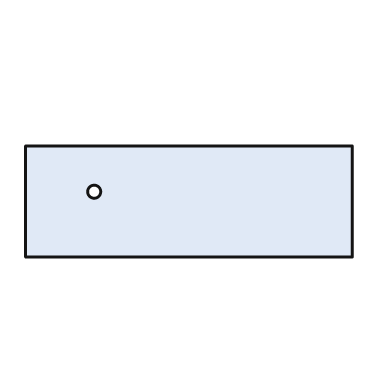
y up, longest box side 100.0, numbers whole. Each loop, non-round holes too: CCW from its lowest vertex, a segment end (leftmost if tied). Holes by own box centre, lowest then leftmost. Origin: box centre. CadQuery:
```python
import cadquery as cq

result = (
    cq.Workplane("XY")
    .moveTo(-50.0, -17.0)
    .lineTo(50.0, -17.0)
    .lineTo(50.0, 17.0)
    .lineTo(-50.0, 17.0)
    .close()
    .moveTo(-29.0, 3.0)
    .circle(2.0)
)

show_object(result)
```